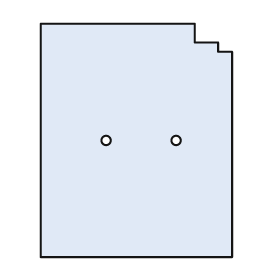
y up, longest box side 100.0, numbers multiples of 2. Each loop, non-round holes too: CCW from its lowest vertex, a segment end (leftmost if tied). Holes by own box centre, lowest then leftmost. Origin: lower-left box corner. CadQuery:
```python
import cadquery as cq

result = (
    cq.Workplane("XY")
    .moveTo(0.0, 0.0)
    .lineTo(82.0, 0.0)
    .lineTo(82.0, 88.0)
    .lineTo(76.0, 88.0)
    .lineTo(76.0, 92.0)
    .lineTo(66.0, 92.0)
    .lineTo(66.0, 100.0)
    .lineTo(0.0, 100.0)
    .close()
    .moveTo(28.0, 50.0)
    .circle(2.0)
    .moveTo(58.0, 50.0)
    .circle(2.0)
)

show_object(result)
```